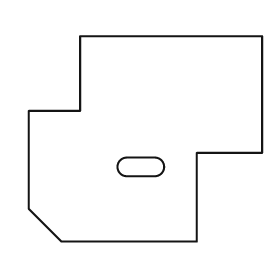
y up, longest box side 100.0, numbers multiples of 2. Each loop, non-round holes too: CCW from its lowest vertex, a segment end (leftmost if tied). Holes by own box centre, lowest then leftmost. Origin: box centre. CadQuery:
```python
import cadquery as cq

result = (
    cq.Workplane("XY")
    .moveTo(-36.0, -44.0)
    .lineTo(22.0, -44.0)
    .lineTo(22.0, -6.0)
    .lineTo(50.0, -6.0)
    .lineTo(50.0, 44.0)
    .lineTo(-28.0, 44.0)
    .lineTo(-28.0, 12.0)
    .lineTo(-50.0, 12.0)
    .lineTo(-50.0, -30.0)
    .close()
    .moveTo(-8.0, -16.0)
    .lineTo(4.0, -16.0)
    .threePointArc((8.0, -12.0), (4.0, -8.0))
    .lineTo(-8.0, -8.0)
    .threePointArc((-12.0, -12.0), (-8.0, -16.0))
    .close()
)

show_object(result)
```